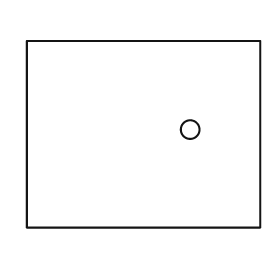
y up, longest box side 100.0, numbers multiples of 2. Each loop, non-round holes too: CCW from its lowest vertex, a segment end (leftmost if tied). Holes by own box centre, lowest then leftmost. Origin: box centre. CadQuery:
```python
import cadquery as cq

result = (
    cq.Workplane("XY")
    .moveTo(-50.0, -40.0)
    .lineTo(50.0, -40.0)
    .lineTo(50.0, 40.0)
    .lineTo(-50.0, 40.0)
    .close()
    .moveTo(20.0, 2.0)
    .circle(4.0)
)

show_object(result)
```